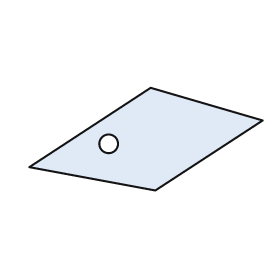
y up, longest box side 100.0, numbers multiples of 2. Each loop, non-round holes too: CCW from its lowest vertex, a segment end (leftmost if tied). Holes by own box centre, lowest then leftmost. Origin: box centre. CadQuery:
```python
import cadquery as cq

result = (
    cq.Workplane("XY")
    .moveTo(4.0, -22.0)
    .lineTo(50.0, 8.0)
    .lineTo(2.0, 22.0)
    .lineTo(-50.0, -12.0)
    .close()
    .moveTo(-16.0, -2.0)
    .circle(4.0)
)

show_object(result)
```